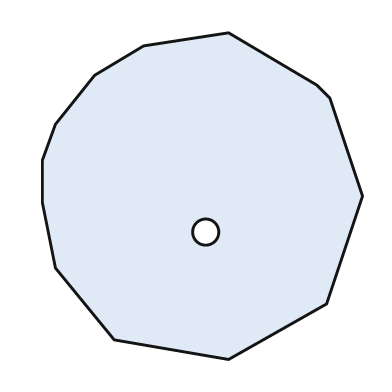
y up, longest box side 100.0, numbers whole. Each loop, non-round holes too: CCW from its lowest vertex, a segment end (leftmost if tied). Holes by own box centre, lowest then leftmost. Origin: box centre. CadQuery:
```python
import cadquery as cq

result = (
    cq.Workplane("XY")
    .moveTo(8.0, -50.0)
    .lineTo(38.0, -33.0)
    .lineTo(49.0, 0.0)
    .lineTo(39.0, 30.0)
    .lineTo(35.0, 34.0)
    .lineTo(8.0, 50.0)
    .lineTo(-18.0, 46.0)
    .lineTo(-33.0, 37.0)
    .lineTo(-45.0, 22.0)
    .lineTo(-49.0, 11.0)
    .lineTo(-49.0, -2.0)
    .lineTo(-45.0, -22.0)
    .lineTo(-27.0, -44.0)
    .close()
    .moveTo(1.0, -11.0)
    .circle(4.0)
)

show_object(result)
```